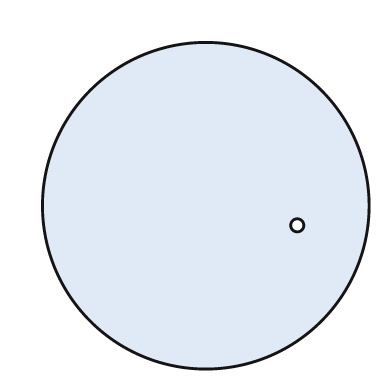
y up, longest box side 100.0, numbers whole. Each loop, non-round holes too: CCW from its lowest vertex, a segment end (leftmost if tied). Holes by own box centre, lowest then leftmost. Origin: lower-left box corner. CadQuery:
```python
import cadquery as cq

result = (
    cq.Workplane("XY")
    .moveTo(50.0, 50.0)
    .circle(50.0)
    .moveTo(78.0, 44.0)
    .circle(2.0)
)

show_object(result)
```